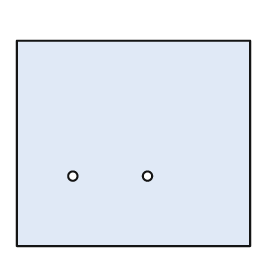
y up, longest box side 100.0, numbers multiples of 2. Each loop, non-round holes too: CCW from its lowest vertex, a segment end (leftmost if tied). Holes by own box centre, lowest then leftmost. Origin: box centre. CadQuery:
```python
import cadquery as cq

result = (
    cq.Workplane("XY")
    .moveTo(-50.0, -44.0)
    .lineTo(50.0, -44.0)
    .lineTo(50.0, 44.0)
    .lineTo(-50.0, 44.0)
    .close()
    .moveTo(-26.0, -14.0)
    .circle(2.0)
    .moveTo(6.0, -14.0)
    .circle(2.0)
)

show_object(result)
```